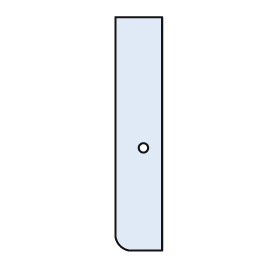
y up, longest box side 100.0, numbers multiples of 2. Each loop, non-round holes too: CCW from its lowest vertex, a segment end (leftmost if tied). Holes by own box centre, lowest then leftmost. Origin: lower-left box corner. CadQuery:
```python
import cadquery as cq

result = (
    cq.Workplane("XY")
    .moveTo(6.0, 0.0)
    .lineTo(20.0, 0.0)
    .lineTo(20.0, 100.0)
    .lineTo(0.0, 100.0)
    .lineTo(0.0, 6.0)
    .threePointArc((2.0, 2.0), (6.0, 0.0))
    .close()
    .moveTo(12.0, 44.0)
    .circle(2.0)
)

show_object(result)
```